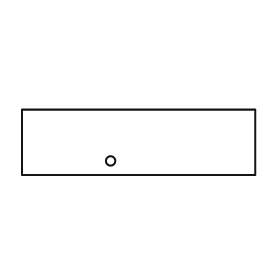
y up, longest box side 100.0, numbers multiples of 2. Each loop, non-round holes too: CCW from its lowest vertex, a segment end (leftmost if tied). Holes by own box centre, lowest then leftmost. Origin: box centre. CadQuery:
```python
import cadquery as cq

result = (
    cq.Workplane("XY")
    .moveTo(-50.0, -14.0)
    .lineTo(50.0, -14.0)
    .lineTo(50.0, 14.0)
    .lineTo(-50.0, 14.0)
    .close()
    .moveTo(-12.0, -8.0)
    .circle(2.0)
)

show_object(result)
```